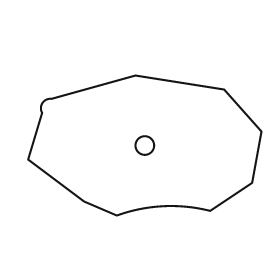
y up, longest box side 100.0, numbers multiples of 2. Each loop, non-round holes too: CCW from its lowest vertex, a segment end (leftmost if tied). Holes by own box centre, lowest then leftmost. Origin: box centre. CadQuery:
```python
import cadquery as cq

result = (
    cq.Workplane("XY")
    .moveTo(-12.0, -30.0)
    .threePointArc((8.0, -26.0), (28.0, -28.0))
    .lineTo(46.0, -16.0)
    .lineTo(50.0, 6.0)
    .lineTo(34.0, 24.0)
    .lineTo(-4.0, 30.0)
    .lineTo(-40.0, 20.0)
    .threePointArc((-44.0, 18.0), (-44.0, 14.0))
    .lineTo(-50.0, -6.0)
    .lineTo(-26.0, -24.0)
    .close()
    .moveTo(0.0, 0.0)
    .circle(4.0)
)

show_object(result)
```